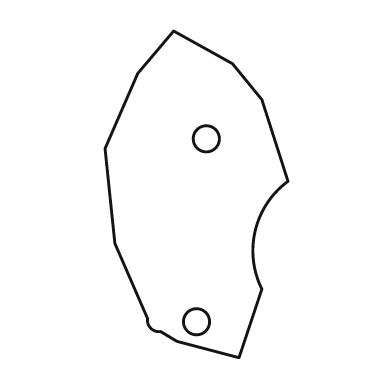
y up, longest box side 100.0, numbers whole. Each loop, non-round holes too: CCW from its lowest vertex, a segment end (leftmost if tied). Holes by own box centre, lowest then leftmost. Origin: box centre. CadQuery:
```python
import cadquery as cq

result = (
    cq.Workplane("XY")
    .moveTo(13.0, -50.0)
    .lineTo(20.0, -29.0)
    .threePointArc((18.0, -11.0), (28.0, 4.0))
    .lineTo(20.0, 29.0)
    .lineTo(11.0, 40.0)
    .lineTo(-7.0, 50.0)
    .lineTo(-18.0, 37.0)
    .lineTo(-28.0, 14.0)
    .lineTo(-25.0, -15.0)
    .lineTo(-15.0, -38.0)
    .threePointArc((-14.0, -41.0), (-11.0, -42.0))
    .lineTo(-6.0, -45.0)
    .close()
    .moveTo(0.0, -39.0)
    .circle(4.0)
    .moveTo(3.0, 17.0)
    .circle(4.0)
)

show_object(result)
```